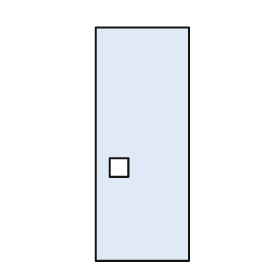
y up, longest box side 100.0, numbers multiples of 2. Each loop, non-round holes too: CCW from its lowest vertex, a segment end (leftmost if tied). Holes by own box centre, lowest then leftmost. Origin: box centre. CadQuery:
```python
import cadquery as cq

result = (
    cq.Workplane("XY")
    .moveTo(-20.0, -50.0)
    .lineTo(20.0, -50.0)
    .lineTo(20.0, 50.0)
    .lineTo(-20.0, 50.0)
    .close()
    .moveTo(-14.0, -14.0)
    .lineTo(-6.0, -14.0)
    .lineTo(-6.0, -6.0)
    .lineTo(-14.0, -6.0)
    .close()
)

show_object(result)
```